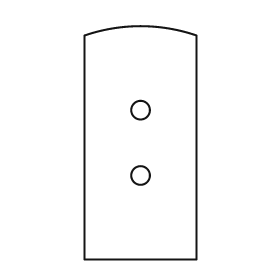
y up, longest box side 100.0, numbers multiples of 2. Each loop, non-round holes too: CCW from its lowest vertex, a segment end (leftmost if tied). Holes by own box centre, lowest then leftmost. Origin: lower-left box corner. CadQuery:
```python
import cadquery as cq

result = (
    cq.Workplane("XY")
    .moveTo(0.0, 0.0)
    .lineTo(48.0, 0.0)
    .lineTo(48.0, 96.0)
    .threePointArc((24.0, 100.0), (0.0, 96.0))
    .close()
    .moveTo(24.0, 36.0)
    .circle(4.0)
    .moveTo(24.0, 64.0)
    .circle(4.0)
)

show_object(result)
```